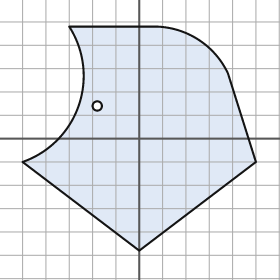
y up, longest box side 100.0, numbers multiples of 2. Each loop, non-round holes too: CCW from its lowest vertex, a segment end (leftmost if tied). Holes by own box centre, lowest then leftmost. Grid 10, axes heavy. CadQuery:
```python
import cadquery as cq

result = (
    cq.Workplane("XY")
    .moveTo(0.0, -48.0)
    .lineTo(50.0, -10.0)
    .lineTo(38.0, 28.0)
    .threePointArc((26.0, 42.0), (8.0, 48.0))
    .lineTo(-30.0, 48.0)
    .threePointArc((-26.0, 14.0), (-50.0, -10.0))
    .close()
    .moveTo(-18.0, 14.0)
    .circle(2.0)
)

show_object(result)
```